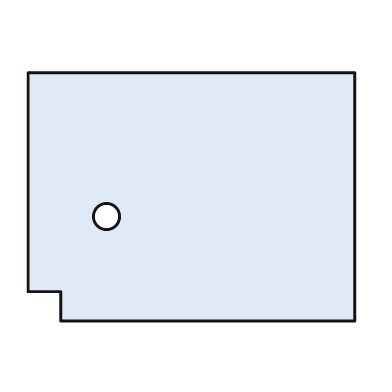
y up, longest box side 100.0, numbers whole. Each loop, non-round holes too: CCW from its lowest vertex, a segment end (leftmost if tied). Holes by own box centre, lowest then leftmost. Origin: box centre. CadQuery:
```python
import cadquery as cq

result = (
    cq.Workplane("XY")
    .moveTo(-40.0, -38.0)
    .lineTo(50.0, -38.0)
    .lineTo(50.0, 38.0)
    .lineTo(-50.0, 38.0)
    .lineTo(-50.0, -29.0)
    .lineTo(-40.0, -29.0)
    .close()
    .moveTo(-26.0, -6.0)
    .circle(4.0)
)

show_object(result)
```